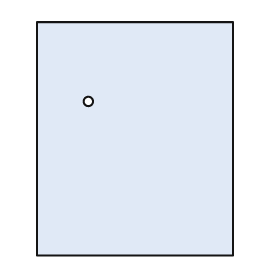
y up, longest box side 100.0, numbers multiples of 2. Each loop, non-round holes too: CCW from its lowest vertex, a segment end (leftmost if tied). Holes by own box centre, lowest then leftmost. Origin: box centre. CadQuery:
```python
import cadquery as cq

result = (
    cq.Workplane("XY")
    .moveTo(-42.0, -50.0)
    .lineTo(42.0, -50.0)
    .lineTo(42.0, 50.0)
    .lineTo(-42.0, 50.0)
    .close()
    .moveTo(-20.0, 16.0)
    .circle(2.0)
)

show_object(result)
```